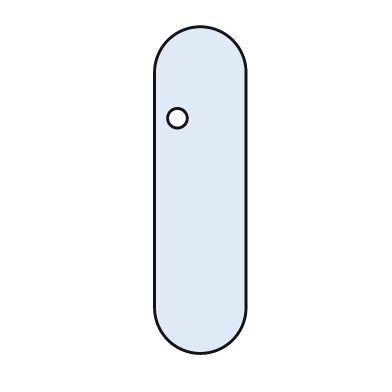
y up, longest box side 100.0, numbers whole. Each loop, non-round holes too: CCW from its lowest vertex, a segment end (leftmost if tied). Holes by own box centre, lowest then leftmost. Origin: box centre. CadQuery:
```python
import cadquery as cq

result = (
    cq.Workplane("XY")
    .moveTo(-14.0, -36.0)
    .threePointArc((0.0, -50.0), (14.0, -36.0))
    .lineTo(14.0, 36.0)
    .threePointArc((0.0, 50.0), (-14.0, 36.0))
    .close()
    .moveTo(-7.0, 22.0)
    .circle(3.0)
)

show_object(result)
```